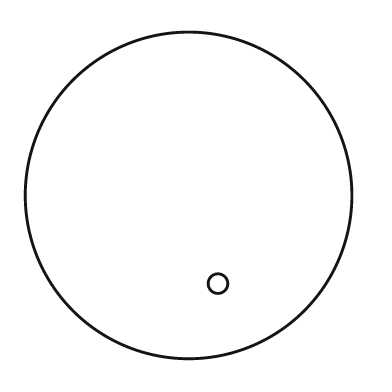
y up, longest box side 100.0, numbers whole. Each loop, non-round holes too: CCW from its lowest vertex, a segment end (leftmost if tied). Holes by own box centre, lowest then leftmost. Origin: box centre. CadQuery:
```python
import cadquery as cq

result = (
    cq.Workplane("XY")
    .moveTo(0.0, 0.0)
    .circle(50.0)
    .moveTo(9.0, -27.0)
    .circle(3.0)
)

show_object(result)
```